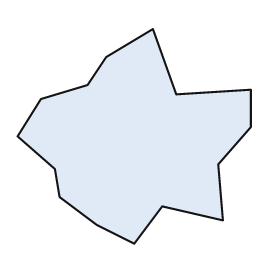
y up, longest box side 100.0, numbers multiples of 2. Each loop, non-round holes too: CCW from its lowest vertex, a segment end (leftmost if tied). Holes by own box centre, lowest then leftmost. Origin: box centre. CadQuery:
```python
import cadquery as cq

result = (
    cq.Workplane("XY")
    .moveTo(0.0, -46.0)
    .lineTo(12.0, -30.0)
    .lineTo(38.0, -36.0)
    .lineTo(36.0, -12.0)
    .lineTo(50.0, 4.0)
    .lineTo(50.0, 20.0)
    .lineTo(18.0, 18.0)
    .lineTo(8.0, 46.0)
    .lineTo(-12.0, 34.0)
    .lineTo(-20.0, 22.0)
    .lineTo(-40.0, 16.0)
    .lineTo(-50.0, 0.0)
    .lineTo(-34.0, -14.0)
    .lineTo(-32.0, -26.0)
    .lineTo(-16.0, -38.0)
    .close()
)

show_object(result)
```